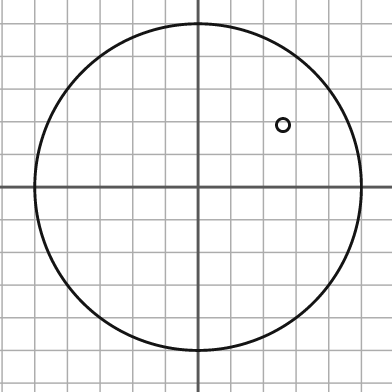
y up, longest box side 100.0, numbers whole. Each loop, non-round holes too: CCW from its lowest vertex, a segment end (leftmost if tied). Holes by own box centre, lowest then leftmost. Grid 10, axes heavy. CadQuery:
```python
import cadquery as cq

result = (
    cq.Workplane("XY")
    .moveTo(0.0, 0.0)
    .circle(50.0)
    .moveTo(26.0, 19.0)
    .circle(2.0)
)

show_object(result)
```